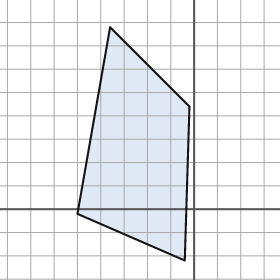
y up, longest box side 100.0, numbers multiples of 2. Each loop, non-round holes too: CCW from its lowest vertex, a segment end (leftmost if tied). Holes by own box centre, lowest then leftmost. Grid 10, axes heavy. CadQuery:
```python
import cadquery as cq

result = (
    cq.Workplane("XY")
    .moveTo(-4.0, -22.0)
    .lineTo(-2.0, 44.0)
    .lineTo(-36.0, 78.0)
    .lineTo(-50.0, -2.0)
    .close()
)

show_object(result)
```